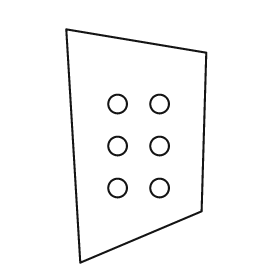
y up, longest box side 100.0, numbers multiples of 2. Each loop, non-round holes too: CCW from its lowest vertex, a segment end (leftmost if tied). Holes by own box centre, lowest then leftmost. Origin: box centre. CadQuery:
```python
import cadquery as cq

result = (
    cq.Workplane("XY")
    .moveTo(-24.0, -50.0)
    .lineTo(28.0, -28.0)
    .lineTo(30.0, 40.0)
    .lineTo(-30.0, 50.0)
    .close()
    .moveTo(-8.0, -18.0)
    .circle(4.0)
    .moveTo(10.0, -18.0)
    .circle(4.0)
    .moveTo(-8.0, 0.0)
    .circle(4.0)
    .moveTo(10.0, 0.0)
    .circle(4.0)
    .moveTo(-8.0, 18.0)
    .circle(4.0)
    .moveTo(10.0, 18.0)
    .circle(4.0)
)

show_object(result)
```